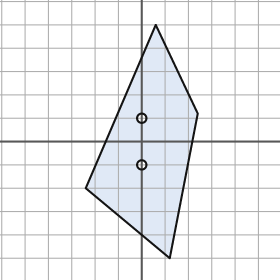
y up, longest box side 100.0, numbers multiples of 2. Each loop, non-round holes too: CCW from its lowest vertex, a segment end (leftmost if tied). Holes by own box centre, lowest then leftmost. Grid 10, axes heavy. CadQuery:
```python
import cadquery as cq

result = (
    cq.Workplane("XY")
    .moveTo(12.0, -50.0)
    .lineTo(24.0, 12.0)
    .lineTo(6.0, 50.0)
    .lineTo(-24.0, -20.0)
    .close()
    .moveTo(0.0, -10.0)
    .circle(2.0)
    .moveTo(0.0, 10.0)
    .circle(2.0)
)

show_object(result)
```